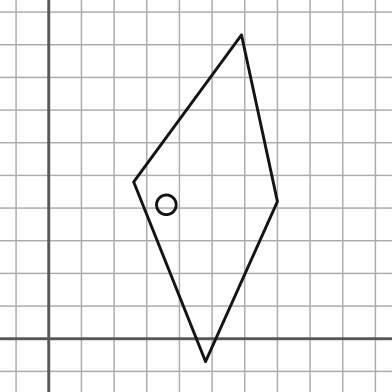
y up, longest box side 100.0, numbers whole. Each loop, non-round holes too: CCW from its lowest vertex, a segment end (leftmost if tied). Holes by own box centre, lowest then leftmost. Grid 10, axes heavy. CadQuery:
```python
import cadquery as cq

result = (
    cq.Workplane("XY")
    .moveTo(48.0, -7.0)
    .lineTo(70.0, 42.0)
    .lineTo(59.0, 93.0)
    .lineTo(26.0, 48.0)
    .close()
    .moveTo(36.0, 41.0)
    .circle(3.0)
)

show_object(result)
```